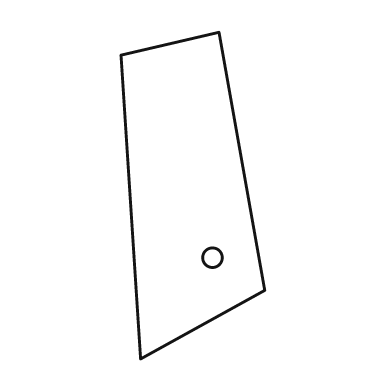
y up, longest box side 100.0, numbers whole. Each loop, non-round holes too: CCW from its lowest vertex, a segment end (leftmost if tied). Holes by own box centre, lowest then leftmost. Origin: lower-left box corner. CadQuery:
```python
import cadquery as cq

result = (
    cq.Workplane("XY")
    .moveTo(6.0, 0.0)
    .lineTo(44.0, 21.0)
    .lineTo(30.0, 100.0)
    .lineTo(0.0, 93.0)
    .close()
    .moveTo(28.0, 31.0)
    .circle(3.0)
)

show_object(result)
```